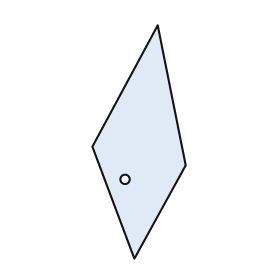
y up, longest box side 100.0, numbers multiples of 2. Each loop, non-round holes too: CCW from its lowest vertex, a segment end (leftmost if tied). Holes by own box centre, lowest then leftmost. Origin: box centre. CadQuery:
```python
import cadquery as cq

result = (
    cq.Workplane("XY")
    .moveTo(-2.0, -50.0)
    .lineTo(20.0, -10.0)
    .lineTo(8.0, 50.0)
    .lineTo(-20.0, -2.0)
    .close()
    .moveTo(-6.0, -16.0)
    .circle(2.0)
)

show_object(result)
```